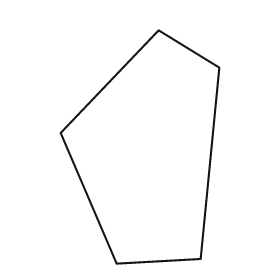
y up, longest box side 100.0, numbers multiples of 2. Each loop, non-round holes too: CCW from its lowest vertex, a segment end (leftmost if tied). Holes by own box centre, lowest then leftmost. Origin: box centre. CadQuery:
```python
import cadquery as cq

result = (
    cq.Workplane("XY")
    .moveTo(-10.0, -50.0)
    .lineTo(26.0, -48.0)
    .lineTo(34.0, 34.0)
    .lineTo(8.0, 50.0)
    .lineTo(-34.0, 6.0)
    .close()
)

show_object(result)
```